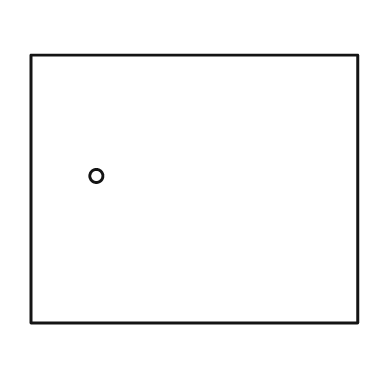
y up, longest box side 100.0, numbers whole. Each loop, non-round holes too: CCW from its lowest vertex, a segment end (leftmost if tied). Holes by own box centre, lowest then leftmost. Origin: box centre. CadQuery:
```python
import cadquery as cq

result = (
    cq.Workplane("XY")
    .moveTo(-50.0, -41.0)
    .lineTo(50.0, -41.0)
    .lineTo(50.0, 41.0)
    .lineTo(-50.0, 41.0)
    .close()
    .moveTo(-30.0, 4.0)
    .circle(2.0)
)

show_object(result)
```